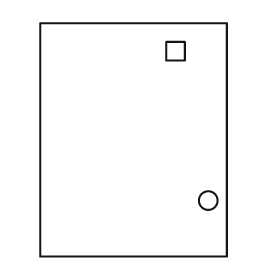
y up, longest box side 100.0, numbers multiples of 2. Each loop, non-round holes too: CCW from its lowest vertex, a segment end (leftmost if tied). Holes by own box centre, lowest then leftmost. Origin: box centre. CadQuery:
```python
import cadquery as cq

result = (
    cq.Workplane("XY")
    .moveTo(-40.0, -50.0)
    .lineTo(40.0, -50.0)
    .lineTo(40.0, 50.0)
    .lineTo(-40.0, 50.0)
    .close()
    .moveTo(32.0, -26.0)
    .circle(4.0)
    .moveTo(14.0, 34.0)
    .lineTo(22.0, 34.0)
    .lineTo(22.0, 42.0)
    .lineTo(14.0, 42.0)
    .close()
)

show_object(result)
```